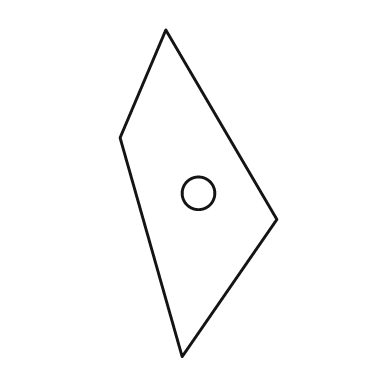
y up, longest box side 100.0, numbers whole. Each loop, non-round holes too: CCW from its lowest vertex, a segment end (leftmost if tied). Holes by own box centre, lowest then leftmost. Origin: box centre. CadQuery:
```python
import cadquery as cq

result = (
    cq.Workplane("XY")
    .moveTo(-5.0, -50.0)
    .lineTo(24.0, -8.0)
    .lineTo(-10.0, 50.0)
    .lineTo(-24.0, 17.0)
    .close()
    .moveTo(0.0, 0.0)
    .circle(5.0)
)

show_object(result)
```